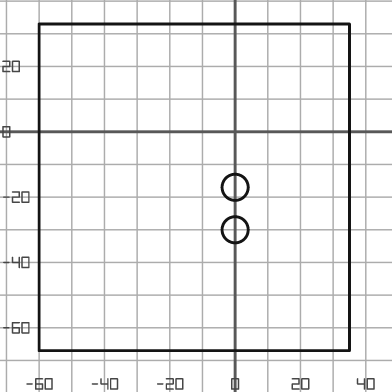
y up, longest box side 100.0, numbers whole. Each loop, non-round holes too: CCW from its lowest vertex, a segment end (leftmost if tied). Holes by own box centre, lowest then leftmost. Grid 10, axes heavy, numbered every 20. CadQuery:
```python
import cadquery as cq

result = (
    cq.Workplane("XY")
    .moveTo(-60.0, -67.0)
    .lineTo(35.0, -67.0)
    .lineTo(35.0, 33.0)
    .lineTo(-60.0, 33.0)
    .close()
    .moveTo(0.0, -30.0)
    .circle(4.0)
    .moveTo(0.0, -17.0)
    .circle(4.0)
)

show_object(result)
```